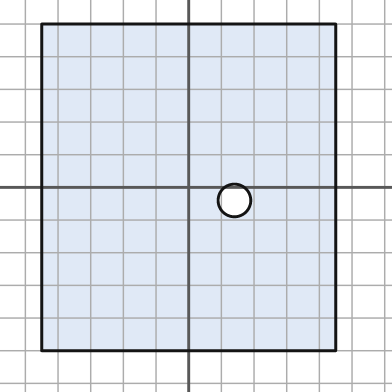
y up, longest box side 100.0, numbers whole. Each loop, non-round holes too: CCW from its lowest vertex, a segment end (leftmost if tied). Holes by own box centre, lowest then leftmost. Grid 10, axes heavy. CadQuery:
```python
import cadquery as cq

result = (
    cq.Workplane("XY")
    .moveTo(-45.0, -50.0)
    .lineTo(45.0, -50.0)
    .lineTo(45.0, 50.0)
    .lineTo(-45.0, 50.0)
    .close()
    .moveTo(14.0, -4.0)
    .circle(5.0)
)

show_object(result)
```